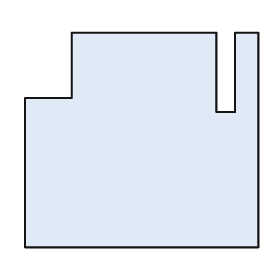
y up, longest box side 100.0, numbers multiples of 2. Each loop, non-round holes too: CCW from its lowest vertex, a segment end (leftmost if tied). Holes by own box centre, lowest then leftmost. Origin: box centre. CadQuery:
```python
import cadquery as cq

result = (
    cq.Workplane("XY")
    .moveTo(-50.0, -46.0)
    .lineTo(50.0, -46.0)
    .lineTo(50.0, 46.0)
    .lineTo(40.0, 46.0)
    .lineTo(40.0, 12.0)
    .lineTo(32.0, 12.0)
    .lineTo(32.0, 46.0)
    .lineTo(-30.0, 46.0)
    .lineTo(-30.0, 18.0)
    .lineTo(-50.0, 18.0)
    .close()
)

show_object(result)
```